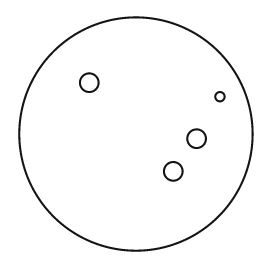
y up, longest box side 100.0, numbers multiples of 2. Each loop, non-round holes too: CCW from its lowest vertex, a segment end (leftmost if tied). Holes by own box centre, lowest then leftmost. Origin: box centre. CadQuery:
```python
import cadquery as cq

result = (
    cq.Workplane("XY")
    .moveTo(0.0, 0.0)
    .circle(50.0)
    .moveTo(16.0, -16.0)
    .circle(4.0)
    .moveTo(26.0, -2.0)
    .circle(4.0)
    .moveTo(36.0, 16.0)
    .circle(2.0)
    .moveTo(-20.0, 22.0)
    .circle(4.0)
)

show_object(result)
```